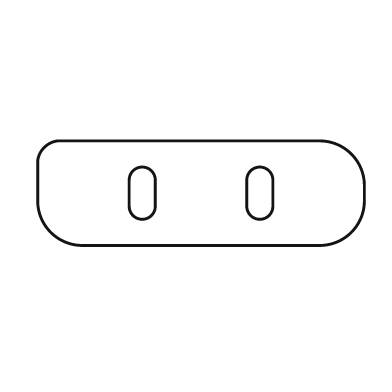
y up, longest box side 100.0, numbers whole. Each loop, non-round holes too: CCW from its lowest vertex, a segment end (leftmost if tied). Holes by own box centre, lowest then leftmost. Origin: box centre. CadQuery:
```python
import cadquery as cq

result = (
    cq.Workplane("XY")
    .moveTo(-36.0, -16.0)
    .lineTo(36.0, -16.0)
    .threePointArc((46.0, -12.0), (50.0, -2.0))
    .lineTo(50.0, 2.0)
    .threePointArc((46.0, 12.0), (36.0, 16.0))
    .lineTo(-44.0, 16.0)
    .threePointArc((-48.0, 14.0), (-50.0, 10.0))
    .lineTo(-50.0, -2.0)
    .threePointArc((-46.0, -12.0), (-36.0, -16.0))
    .close()
    .moveTo(-22.0, -4.0)
    .threePointArc((-18.0, -8.0), (-14.0, -4.0))
    .lineTo(-14.0, 4.0)
    .threePointArc((-18.0, 8.0), (-22.0, 4.0))
    .close()
    .moveTo(14.0, -4.0)
    .threePointArc((18.0, -8.0), (22.0, -4.0))
    .lineTo(22.0, 4.0)
    .threePointArc((18.0, 8.0), (14.0, 4.0))
    .close()
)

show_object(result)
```